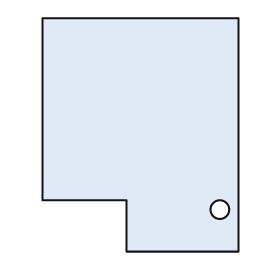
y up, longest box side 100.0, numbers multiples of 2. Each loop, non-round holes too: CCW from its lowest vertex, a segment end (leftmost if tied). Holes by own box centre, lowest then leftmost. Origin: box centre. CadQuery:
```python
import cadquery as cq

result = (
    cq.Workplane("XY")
    .moveTo(-6.0, -50.0)
    .lineTo(42.0, -50.0)
    .lineTo(42.0, 50.0)
    .lineTo(-42.0, 50.0)
    .lineTo(-42.0, -28.0)
    .lineTo(-6.0, -28.0)
    .close()
    .moveTo(34.0, -32.0)
    .circle(4.0)
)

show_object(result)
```